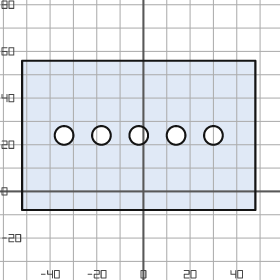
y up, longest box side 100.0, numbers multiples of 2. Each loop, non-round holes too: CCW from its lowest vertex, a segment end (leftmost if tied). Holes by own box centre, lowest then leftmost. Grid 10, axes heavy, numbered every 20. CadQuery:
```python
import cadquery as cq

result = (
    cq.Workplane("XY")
    .moveTo(-52.0, -8.0)
    .lineTo(48.0, -8.0)
    .lineTo(48.0, 56.0)
    .lineTo(-52.0, 56.0)
    .close()
    .moveTo(-34.0, 24.0)
    .circle(4.0)
    .moveTo(-18.0, 24.0)
    .circle(4.0)
    .moveTo(-2.0, 24.0)
    .circle(4.0)
    .moveTo(14.0, 24.0)
    .circle(4.0)
    .moveTo(30.0, 24.0)
    .circle(4.0)
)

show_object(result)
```